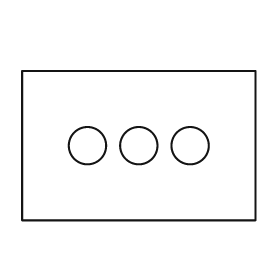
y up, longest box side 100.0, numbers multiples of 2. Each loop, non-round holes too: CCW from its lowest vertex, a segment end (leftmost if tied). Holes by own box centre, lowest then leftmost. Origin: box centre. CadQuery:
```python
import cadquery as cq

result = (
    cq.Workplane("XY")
    .moveTo(-50.0, -32.0)
    .lineTo(50.0, -32.0)
    .lineTo(50.0, 32.0)
    .lineTo(-50.0, 32.0)
    .close()
    .moveTo(-22.0, 0.0)
    .circle(8.0)
    .moveTo(0.0, 0.0)
    .circle(8.0)
    .moveTo(22.0, 0.0)
    .circle(8.0)
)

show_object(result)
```